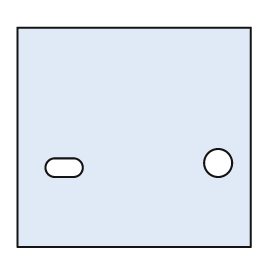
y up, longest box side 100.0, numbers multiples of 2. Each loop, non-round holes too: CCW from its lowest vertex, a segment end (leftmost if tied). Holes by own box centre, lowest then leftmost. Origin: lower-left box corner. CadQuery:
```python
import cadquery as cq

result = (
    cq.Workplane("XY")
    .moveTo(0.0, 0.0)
    .lineTo(100.0, 0.0)
    .lineTo(100.0, 94.0)
    .lineTo(0.0, 94.0)
    .close()
    .moveTo(16.0, 30.0)
    .lineTo(24.0, 30.0)
    .threePointArc((28.0, 34.0), (24.0, 38.0))
    .lineTo(16.0, 38.0)
    .threePointArc((12.0, 34.0), (16.0, 30.0))
    .close()
    .moveTo(86.0, 36.0)
    .circle(6.0)
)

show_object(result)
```